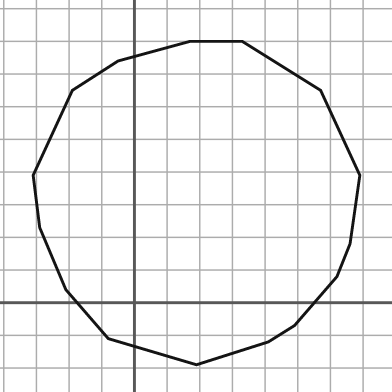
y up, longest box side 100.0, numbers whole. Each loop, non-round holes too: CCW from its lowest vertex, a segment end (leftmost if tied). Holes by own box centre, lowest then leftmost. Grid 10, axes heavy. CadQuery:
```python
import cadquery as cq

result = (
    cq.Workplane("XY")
    .moveTo(19.0, -19.0)
    .lineTo(41.0, -12.0)
    .lineTo(49.0, -7.0)
    .lineTo(62.0, 8.0)
    .lineTo(66.0, 18.0)
    .lineTo(69.0, 39.0)
    .lineTo(57.0, 65.0)
    .lineTo(33.0, 80.0)
    .lineTo(17.0, 80.0)
    .lineTo(-5.0, 74.0)
    .lineTo(-19.0, 65.0)
    .lineTo(-31.0, 39.0)
    .lineTo(-29.0, 23.0)
    .lineTo(-21.0, 4.0)
    .lineTo(-8.0, -11.0)
    .close()
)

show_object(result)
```